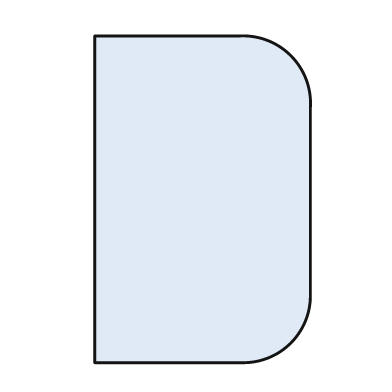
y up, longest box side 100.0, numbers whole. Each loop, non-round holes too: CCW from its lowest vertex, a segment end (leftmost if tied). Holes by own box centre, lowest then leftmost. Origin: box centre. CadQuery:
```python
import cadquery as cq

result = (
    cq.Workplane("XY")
    .moveTo(-33.0, -50.0)
    .lineTo(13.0, -50.0)
    .threePointArc((27.0, -44.0), (33.0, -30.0))
    .lineTo(33.0, 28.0)
    .threePointArc((27.0, 44.0), (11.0, 50.0))
    .lineTo(-33.0, 50.0)
    .close()
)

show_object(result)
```